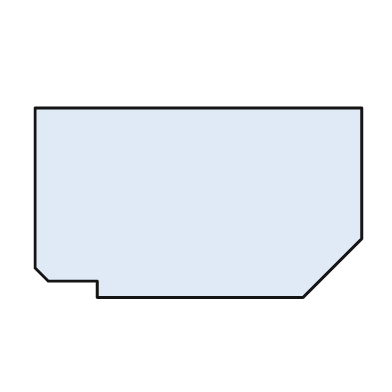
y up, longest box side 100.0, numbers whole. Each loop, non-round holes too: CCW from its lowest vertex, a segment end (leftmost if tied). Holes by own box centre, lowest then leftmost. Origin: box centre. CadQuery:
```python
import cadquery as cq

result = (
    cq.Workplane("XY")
    .moveTo(-31.0, -29.0)
    .lineTo(32.0, -29.0)
    .lineTo(50.0, -11.0)
    .lineTo(50.0, 29.0)
    .lineTo(-50.0, 29.0)
    .lineTo(-50.0, -20.0)
    .lineTo(-46.0, -24.0)
    .lineTo(-31.0, -24.0)
    .close()
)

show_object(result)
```